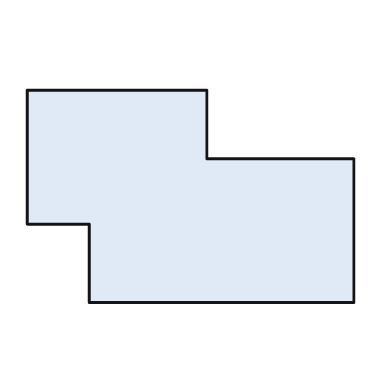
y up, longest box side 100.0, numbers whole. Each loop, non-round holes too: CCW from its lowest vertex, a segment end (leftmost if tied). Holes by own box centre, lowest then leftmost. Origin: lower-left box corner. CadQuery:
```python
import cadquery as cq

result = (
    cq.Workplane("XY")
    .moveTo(19.0, 0.0)
    .lineTo(100.0, 0.0)
    .lineTo(100.0, 44.0)
    .lineTo(55.0, 44.0)
    .lineTo(55.0, 65.0)
    .lineTo(0.0, 65.0)
    .lineTo(0.0, 24.0)
    .lineTo(19.0, 24.0)
    .close()
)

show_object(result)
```